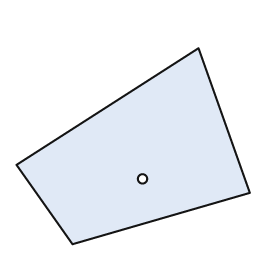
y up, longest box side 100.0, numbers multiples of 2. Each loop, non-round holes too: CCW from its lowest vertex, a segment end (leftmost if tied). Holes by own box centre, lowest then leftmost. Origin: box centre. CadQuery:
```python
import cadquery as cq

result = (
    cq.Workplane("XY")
    .moveTo(-26.0, -42.0)
    .lineTo(50.0, -20.0)
    .lineTo(28.0, 42.0)
    .lineTo(-50.0, -8.0)
    .close()
    .moveTo(4.0, -14.0)
    .circle(2.0)
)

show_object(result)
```